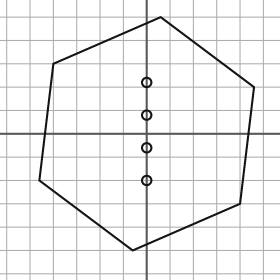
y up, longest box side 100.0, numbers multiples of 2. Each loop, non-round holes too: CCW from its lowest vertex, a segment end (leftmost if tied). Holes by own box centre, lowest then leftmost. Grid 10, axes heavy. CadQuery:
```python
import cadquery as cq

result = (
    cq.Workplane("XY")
    .moveTo(-6.0, -50.0)
    .lineTo(40.0, -30.0)
    .lineTo(46.0, 20.0)
    .lineTo(6.0, 50.0)
    .lineTo(-40.0, 30.0)
    .lineTo(-46.0, -20.0)
    .close()
    .moveTo(0.0, -20.0)
    .circle(2.0)
    .moveTo(0.0, -6.0)
    .circle(2.0)
    .moveTo(0.0, 8.0)
    .circle(2.0)
    .moveTo(0.0, 22.0)
    .circle(2.0)
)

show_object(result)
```